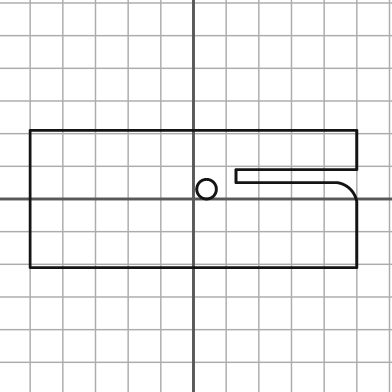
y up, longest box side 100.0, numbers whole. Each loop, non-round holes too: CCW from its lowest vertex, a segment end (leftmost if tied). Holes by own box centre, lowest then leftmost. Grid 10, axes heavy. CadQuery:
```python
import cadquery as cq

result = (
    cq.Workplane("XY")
    .moveTo(-50.0, -21.0)
    .lineTo(50.0, -21.0)
    .lineTo(50.0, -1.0)
    .threePointArc((48.0, 3.0), (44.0, 5.0))
    .lineTo(13.0, 5.0)
    .lineTo(13.0, 9.0)
    .lineTo(50.0, 9.0)
    .lineTo(50.0, 21.0)
    .lineTo(-50.0, 21.0)
    .close()
    .moveTo(4.0, 3.0)
    .circle(3.0)
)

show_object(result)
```